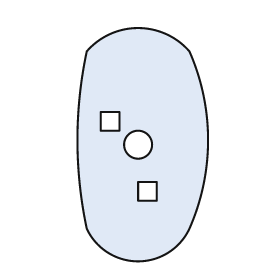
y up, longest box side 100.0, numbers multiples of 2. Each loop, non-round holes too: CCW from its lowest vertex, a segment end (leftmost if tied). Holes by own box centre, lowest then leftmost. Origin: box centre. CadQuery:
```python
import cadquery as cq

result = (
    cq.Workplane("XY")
    .moveTo(-24.0, -36.0)
    .threePointArc((-2.0, -50.0), (20.0, -36.0))
    .threePointArc((28.0, 2.0), (20.0, 40.0))
    .threePointArc((-2.0, 50.0), (-24.0, 40.0))
    .threePointArc((-28.0, 2.0), (-24.0, -36.0))
    .close()
    .moveTo(-2.0, -24.0)
    .lineTo(6.0, -24.0)
    .lineTo(6.0, -16.0)
    .lineTo(-2.0, -16.0)
    .close()
    .moveTo(-2.0, 0.0)
    .circle(6.0)
    .moveTo(-18.0, 6.0)
    .lineTo(-10.0, 6.0)
    .lineTo(-10.0, 14.0)
    .lineTo(-18.0, 14.0)
    .close()
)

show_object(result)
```